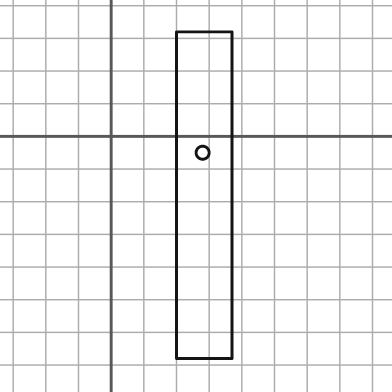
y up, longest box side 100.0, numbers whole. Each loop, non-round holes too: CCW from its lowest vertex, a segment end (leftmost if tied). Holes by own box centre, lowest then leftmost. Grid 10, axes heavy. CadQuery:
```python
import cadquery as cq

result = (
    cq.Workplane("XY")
    .moveTo(20.0, -68.0)
    .lineTo(37.0, -68.0)
    .lineTo(37.0, 32.0)
    .lineTo(20.0, 32.0)
    .close()
    .moveTo(28.0, -5.0)
    .circle(2.0)
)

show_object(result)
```